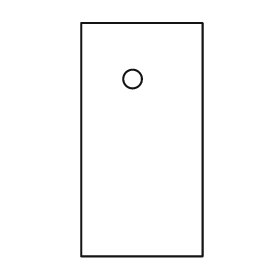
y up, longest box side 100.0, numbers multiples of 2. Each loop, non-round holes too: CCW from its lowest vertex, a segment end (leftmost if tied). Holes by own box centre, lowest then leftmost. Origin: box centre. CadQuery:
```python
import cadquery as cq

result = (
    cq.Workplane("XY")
    .moveTo(-26.0, -50.0)
    .lineTo(26.0, -50.0)
    .lineTo(26.0, 50.0)
    .lineTo(-26.0, 50.0)
    .close()
    .moveTo(-4.0, 26.0)
    .circle(4.0)
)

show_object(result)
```